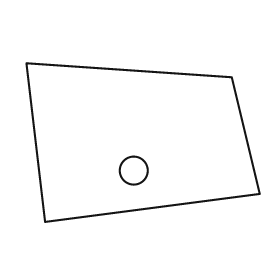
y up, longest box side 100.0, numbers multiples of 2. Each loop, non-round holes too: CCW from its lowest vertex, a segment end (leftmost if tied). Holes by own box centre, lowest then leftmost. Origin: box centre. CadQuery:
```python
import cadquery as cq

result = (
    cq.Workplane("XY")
    .moveTo(-42.0, -34.0)
    .lineTo(50.0, -22.0)
    .lineTo(38.0, 28.0)
    .lineTo(-50.0, 34.0)
    .close()
    .moveTo(-4.0, -12.0)
    .circle(6.0)
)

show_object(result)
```